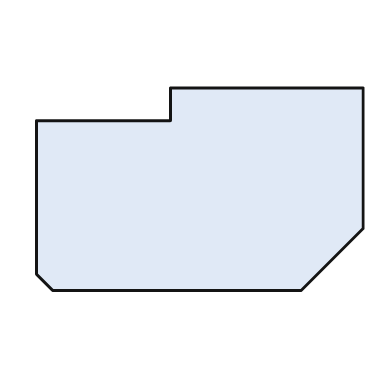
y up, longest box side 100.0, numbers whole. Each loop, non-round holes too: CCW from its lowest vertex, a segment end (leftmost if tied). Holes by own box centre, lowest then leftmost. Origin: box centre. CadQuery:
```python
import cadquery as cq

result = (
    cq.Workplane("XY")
    .moveTo(-45.0, -31.0)
    .lineTo(31.0, -31.0)
    .lineTo(50.0, -12.0)
    .lineTo(50.0, 31.0)
    .lineTo(-9.0, 31.0)
    .lineTo(-9.0, 21.0)
    .lineTo(-50.0, 21.0)
    .lineTo(-50.0, -26.0)
    .close()
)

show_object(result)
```